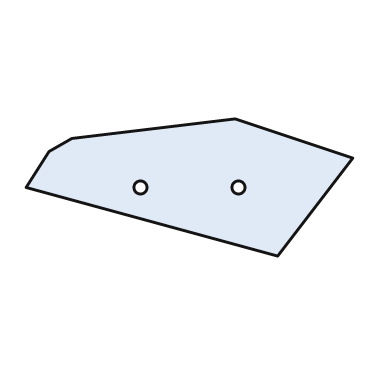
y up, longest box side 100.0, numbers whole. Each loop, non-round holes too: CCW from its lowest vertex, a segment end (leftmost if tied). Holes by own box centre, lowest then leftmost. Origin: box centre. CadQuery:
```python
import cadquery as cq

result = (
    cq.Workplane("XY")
    .moveTo(27.0, -21.0)
    .lineTo(50.0, 9.0)
    .lineTo(14.0, 21.0)
    .lineTo(-36.0, 15.0)
    .lineTo(-43.0, 11.0)
    .lineTo(-50.0, 0.0)
    .close()
    .moveTo(-15.0, 0.0)
    .circle(2.0)
    .moveTo(15.0, 0.0)
    .circle(2.0)
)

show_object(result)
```